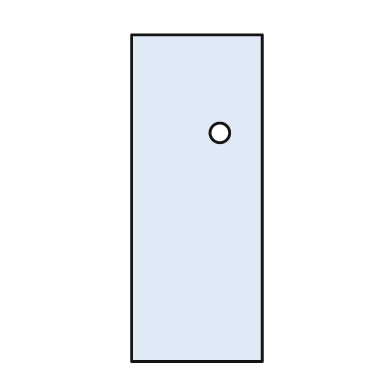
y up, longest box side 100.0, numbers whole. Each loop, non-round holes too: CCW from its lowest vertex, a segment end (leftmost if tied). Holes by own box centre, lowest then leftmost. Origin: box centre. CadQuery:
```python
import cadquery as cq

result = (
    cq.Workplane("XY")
    .moveTo(-20.0, -50.0)
    .lineTo(20.0, -50.0)
    .lineTo(20.0, 50.0)
    .lineTo(-20.0, 50.0)
    .close()
    .moveTo(7.0, 20.0)
    .circle(3.0)
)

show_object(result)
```